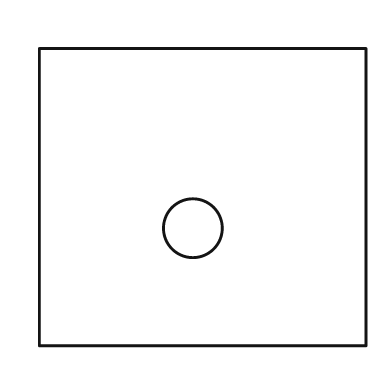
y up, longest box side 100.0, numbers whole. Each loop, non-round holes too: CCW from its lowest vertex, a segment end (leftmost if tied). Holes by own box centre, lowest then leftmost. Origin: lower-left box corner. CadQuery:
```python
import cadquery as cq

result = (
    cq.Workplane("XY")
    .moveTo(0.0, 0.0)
    .lineTo(100.0, 0.0)
    .lineTo(100.0, 91.0)
    .lineTo(0.0, 91.0)
    .close()
    .moveTo(47.0, 36.0)
    .circle(9.0)
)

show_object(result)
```